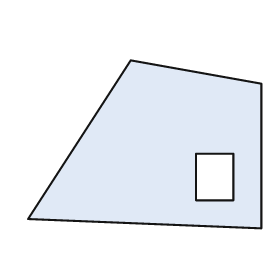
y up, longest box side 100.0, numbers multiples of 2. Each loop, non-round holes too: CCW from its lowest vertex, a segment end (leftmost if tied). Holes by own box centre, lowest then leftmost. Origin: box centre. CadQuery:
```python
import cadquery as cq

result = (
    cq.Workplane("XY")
    .moveTo(50.0, -36.0)
    .lineTo(50.0, 26.0)
    .lineTo(-6.0, 36.0)
    .lineTo(-50.0, -32.0)
    .close()
    .moveTo(22.0, -24.0)
    .lineTo(38.0, -24.0)
    .lineTo(38.0, -4.0)
    .lineTo(22.0, -4.0)
    .close()
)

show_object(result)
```